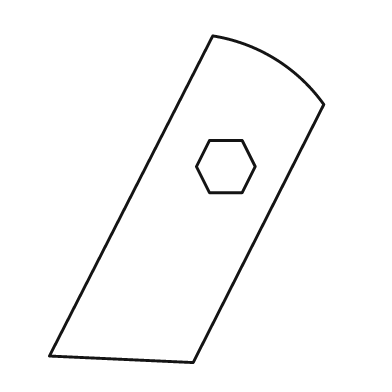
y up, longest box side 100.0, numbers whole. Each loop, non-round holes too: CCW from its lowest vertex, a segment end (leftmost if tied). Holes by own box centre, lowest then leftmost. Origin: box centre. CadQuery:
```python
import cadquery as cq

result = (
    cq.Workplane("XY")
    .moveTo(2.0, -50.0)
    .lineTo(42.0, 29.0)
    .threePointArc((27.0, 43.0), (8.0, 50.0))
    .lineTo(-42.0, -48.0)
    .close()
    .moveTo(7.0, 2.0)
    .lineTo(17.0, 2.0)
    .lineTo(21.0, 10.0)
    .lineTo(17.0, 18.0)
    .lineTo(7.0, 18.0)
    .lineTo(3.0, 10.0)
    .close()
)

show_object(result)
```